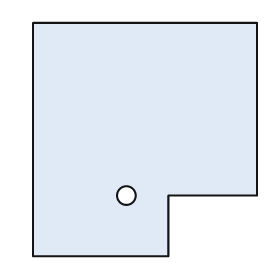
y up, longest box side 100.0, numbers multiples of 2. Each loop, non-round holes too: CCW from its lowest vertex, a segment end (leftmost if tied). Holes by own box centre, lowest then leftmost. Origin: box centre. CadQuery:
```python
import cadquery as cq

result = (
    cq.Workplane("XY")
    .moveTo(-48.0, -50.0)
    .lineTo(10.0, -50.0)
    .lineTo(10.0, -24.0)
    .lineTo(48.0, -24.0)
    .lineTo(48.0, 50.0)
    .lineTo(-48.0, 50.0)
    .close()
    .moveTo(-8.0, -24.0)
    .circle(4.0)
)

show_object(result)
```